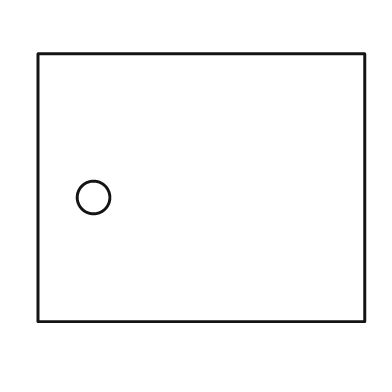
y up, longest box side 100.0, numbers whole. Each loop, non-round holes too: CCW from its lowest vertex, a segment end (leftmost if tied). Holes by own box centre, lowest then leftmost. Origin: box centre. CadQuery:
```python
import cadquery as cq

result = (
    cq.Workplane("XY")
    .moveTo(-50.0, -41.0)
    .lineTo(50.0, -41.0)
    .lineTo(50.0, 41.0)
    .lineTo(-50.0, 41.0)
    .close()
    .moveTo(-33.0, -3.0)
    .circle(5.0)
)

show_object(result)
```